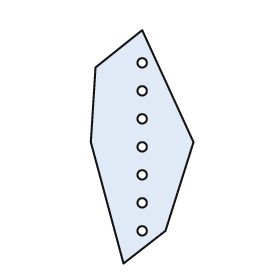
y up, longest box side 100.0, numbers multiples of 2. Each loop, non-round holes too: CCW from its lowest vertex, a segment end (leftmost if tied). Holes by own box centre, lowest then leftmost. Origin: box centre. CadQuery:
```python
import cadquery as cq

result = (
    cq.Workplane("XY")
    .moveTo(-8.0, -50.0)
    .lineTo(10.0, -36.0)
    .lineTo(22.0, 2.0)
    .lineTo(0.0, 50.0)
    .lineTo(-20.0, 34.0)
    .lineTo(-22.0, 2.0)
    .close()
    .moveTo(0.0, -36.0)
    .circle(2.0)
    .moveTo(0.0, -24.0)
    .circle(2.0)
    .moveTo(0.0, -12.0)
    .circle(2.0)
    .moveTo(0.0, 0.0)
    .circle(2.0)
    .moveTo(0.0, 12.0)
    .circle(2.0)
    .moveTo(0.0, 24.0)
    .circle(2.0)
    .moveTo(0.0, 36.0)
    .circle(2.0)
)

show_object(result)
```